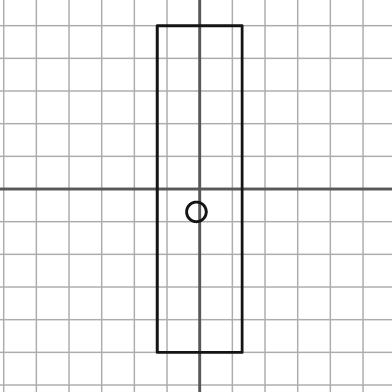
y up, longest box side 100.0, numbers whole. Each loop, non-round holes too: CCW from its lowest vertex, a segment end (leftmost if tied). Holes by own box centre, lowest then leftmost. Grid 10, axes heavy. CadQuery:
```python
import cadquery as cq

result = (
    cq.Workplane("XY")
    .moveTo(-13.0, -50.0)
    .lineTo(13.0, -50.0)
    .lineTo(13.0, 50.0)
    .lineTo(-13.0, 50.0)
    .close()
    .moveTo(-1.0, -7.0)
    .circle(3.0)
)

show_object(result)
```